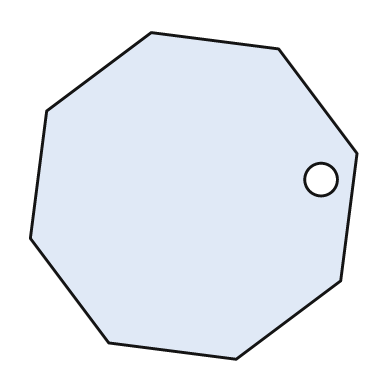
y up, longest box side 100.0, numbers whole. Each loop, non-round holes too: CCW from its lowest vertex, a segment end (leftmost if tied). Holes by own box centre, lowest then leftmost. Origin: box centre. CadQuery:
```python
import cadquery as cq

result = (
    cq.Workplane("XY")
    .moveTo(13.0, -50.0)
    .lineTo(45.0, -26.0)
    .lineTo(50.0, 13.0)
    .lineTo(26.0, 45.0)
    .lineTo(-13.0, 50.0)
    .lineTo(-45.0, 26.0)
    .lineTo(-50.0, -13.0)
    .lineTo(-26.0, -45.0)
    .close()
    .moveTo(39.0, 5.0)
    .circle(5.0)
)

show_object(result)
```